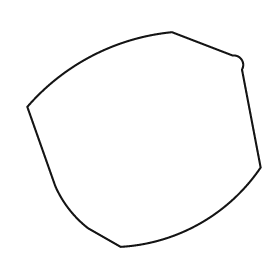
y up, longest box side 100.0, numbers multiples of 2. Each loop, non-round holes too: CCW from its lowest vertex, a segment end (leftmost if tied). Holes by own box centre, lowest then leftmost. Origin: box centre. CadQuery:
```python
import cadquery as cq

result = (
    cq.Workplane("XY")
    .moveTo(-10.0, -46.0)
    .threePointArc((24.0, -36.0), (50.0, -12.0))
    .lineTo(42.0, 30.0)
    .threePointArc((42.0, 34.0), (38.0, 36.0))
    .lineTo(12.0, 46.0)
    .threePointArc((-22.0, 36.0), (-50.0, 14.0))
    .lineTo(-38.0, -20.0)
    .threePointArc((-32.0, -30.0), (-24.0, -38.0))
    .close()
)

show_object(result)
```